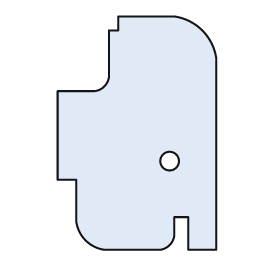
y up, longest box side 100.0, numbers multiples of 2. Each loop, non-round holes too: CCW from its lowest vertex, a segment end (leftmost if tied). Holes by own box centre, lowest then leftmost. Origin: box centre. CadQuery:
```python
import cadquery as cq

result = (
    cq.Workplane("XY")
    .moveTo(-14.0, -50.0)
    .lineTo(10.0, -50.0)
    .threePointArc((14.0, -48.0), (16.0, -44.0))
    .lineTo(16.0, -36.0)
    .lineTo(22.0, -36.0)
    .lineTo(22.0, -50.0)
    .lineTo(34.0, -50.0)
    .lineTo(34.0, 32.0)
    .threePointArc((28.0, 44.0), (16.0, 50.0))
    .lineTo(-8.0, 50.0)
    .lineTo(-8.0, 44.0)
    .lineTo(-12.0, 44.0)
    .lineTo(-12.0, 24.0)
    .threePointArc((-14.0, 20.0), (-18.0, 18.0))
    .lineTo(-34.0, 18.0)
    .lineTo(-34.0, -20.0)
    .lineTo(-26.0, -20.0)
    .lineTo(-26.0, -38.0)
    .threePointArc((-22.0, -46.0), (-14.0, -50.0))
    .close()
    .moveTo(14.0, -12.0)
    .circle(4.0)
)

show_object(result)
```